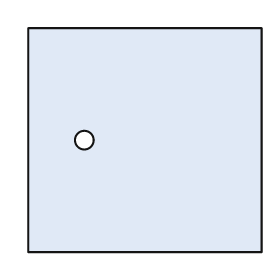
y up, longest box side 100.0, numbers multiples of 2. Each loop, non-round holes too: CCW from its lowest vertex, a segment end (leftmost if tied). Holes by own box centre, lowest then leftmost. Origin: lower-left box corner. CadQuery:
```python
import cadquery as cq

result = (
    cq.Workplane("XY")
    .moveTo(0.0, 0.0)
    .lineTo(100.0, 0.0)
    .lineTo(100.0, 96.0)
    .lineTo(0.0, 96.0)
    .close()
    .moveTo(24.0, 48.0)
    .circle(4.0)
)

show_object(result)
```